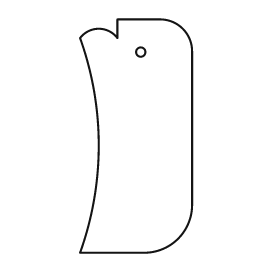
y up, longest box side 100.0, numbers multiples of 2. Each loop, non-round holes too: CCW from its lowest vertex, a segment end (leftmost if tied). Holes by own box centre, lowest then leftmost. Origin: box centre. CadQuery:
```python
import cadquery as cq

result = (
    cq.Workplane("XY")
    .moveTo(-24.0, -50.0)
    .lineTo(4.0, -50.0)
    .threePointArc((18.0, -44.0), (24.0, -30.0))
    .lineTo(24.0, 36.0)
    .threePointArc((20.0, 46.0), (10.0, 50.0))
    .lineTo(-8.0, 50.0)
    .lineTo(-8.0, 42.0)
    .threePointArc((-16.0, 46.0), (-24.0, 42.0))
    .threePointArc((-16.0, -4.0), (-24.0, -50.0))
    .close()
    .moveTo(2.0, 36.0)
    .circle(2.0)
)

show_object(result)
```